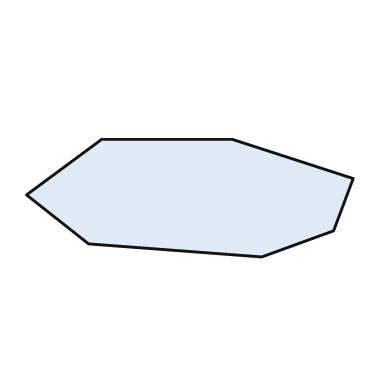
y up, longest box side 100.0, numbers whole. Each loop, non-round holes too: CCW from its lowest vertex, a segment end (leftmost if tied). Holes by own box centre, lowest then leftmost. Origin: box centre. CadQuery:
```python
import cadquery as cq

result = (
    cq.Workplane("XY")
    .moveTo(22.0, -18.0)
    .lineTo(44.0, -10.0)
    .lineTo(50.0, 6.0)
    .lineTo(13.0, 18.0)
    .lineTo(-27.0, 18.0)
    .lineTo(-50.0, 1.0)
    .lineTo(-31.0, -14.0)
    .close()
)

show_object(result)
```